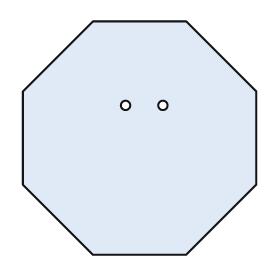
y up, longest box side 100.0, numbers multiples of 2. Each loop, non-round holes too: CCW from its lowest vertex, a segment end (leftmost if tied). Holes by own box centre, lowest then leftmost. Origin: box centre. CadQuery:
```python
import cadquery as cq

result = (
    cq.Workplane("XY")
    .moveTo(-20.0, -50.0)
    .lineTo(20.0, -50.0)
    .lineTo(50.0, -20.0)
    .lineTo(50.0, 20.0)
    .lineTo(20.0, 50.0)
    .lineTo(-20.0, 50.0)
    .lineTo(-50.0, 20.0)
    .lineTo(-50.0, -20.0)
    .close()
    .moveTo(-6.0, 14.0)
    .circle(2.0)
    .moveTo(10.0, 14.0)
    .circle(2.0)
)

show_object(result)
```